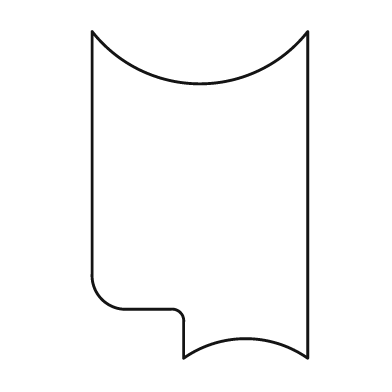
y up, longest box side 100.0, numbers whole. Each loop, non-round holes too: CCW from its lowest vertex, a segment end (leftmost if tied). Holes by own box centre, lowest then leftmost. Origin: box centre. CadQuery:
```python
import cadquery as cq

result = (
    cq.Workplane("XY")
    .moveTo(-5.0, -50.0)
    .threePointArc((14.0, -44.0), (33.0, -50.0))
    .lineTo(33.0, 50.0)
    .threePointArc((0.0, 34.0), (-33.0, 50.0))
    .lineTo(-33.0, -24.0)
    .threePointArc((-30.0, -32.0), (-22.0, -35.0))
    .lineTo(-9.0, -35.0)
    .threePointArc((-6.0, -36.0), (-5.0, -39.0))
    .close()
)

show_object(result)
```